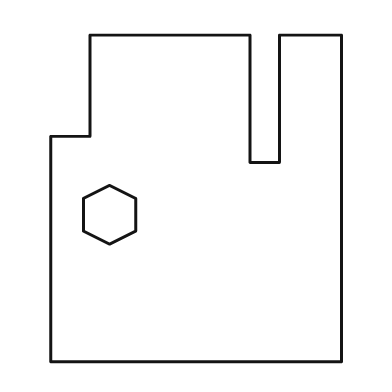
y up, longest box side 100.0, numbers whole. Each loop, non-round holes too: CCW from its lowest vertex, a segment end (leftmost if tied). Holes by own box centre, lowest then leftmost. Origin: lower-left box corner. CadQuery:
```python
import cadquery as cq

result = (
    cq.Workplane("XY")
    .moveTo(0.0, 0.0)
    .lineTo(89.0, 0.0)
    .lineTo(89.0, 100.0)
    .lineTo(70.0, 100.0)
    .lineTo(70.0, 61.0)
    .lineTo(61.0, 61.0)
    .lineTo(61.0, 100.0)
    .lineTo(12.0, 100.0)
    .lineTo(12.0, 69.0)
    .lineTo(0.0, 69.0)
    .close()
    .moveTo(18.0, 36.0)
    .lineTo(26.0, 40.0)
    .lineTo(26.0, 50.0)
    .lineTo(18.0, 54.0)
    .lineTo(10.0, 50.0)
    .lineTo(10.0, 40.0)
    .close()
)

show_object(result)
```